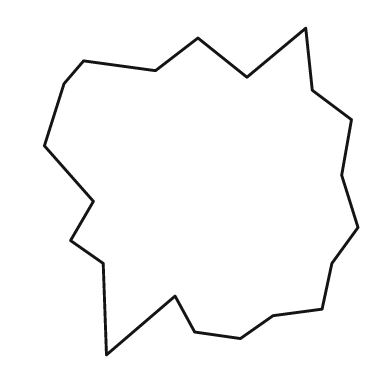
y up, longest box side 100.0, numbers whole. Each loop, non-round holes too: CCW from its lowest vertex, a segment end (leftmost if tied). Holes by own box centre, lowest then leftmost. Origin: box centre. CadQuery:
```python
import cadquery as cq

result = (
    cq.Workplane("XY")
    .moveTo(-29.0, -50.0)
    .lineTo(-8.0, -32.0)
    .lineTo(-2.0, -43.0)
    .lineTo(12.0, -45.0)
    .lineTo(22.0, -38.0)
    .lineTo(37.0, -36.0)
    .lineTo(40.0, -22.0)
    .lineTo(48.0, -11.0)
    .lineTo(43.0, 5.0)
    .lineTo(46.0, 22.0)
    .lineTo(34.0, 31.0)
    .lineTo(32.0, 50.0)
    .lineTo(14.0, 35.0)
    .lineTo(-1.0, 47.0)
    .lineTo(-14.0, 37.0)
    .lineTo(-36.0, 40.0)
    .lineTo(-42.0, 33.0)
    .lineTo(-48.0, 14.0)
    .lineTo(-33.0, -3.0)
    .lineTo(-40.0, -15.0)
    .lineTo(-30.0, -22.0)
    .close()
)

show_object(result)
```